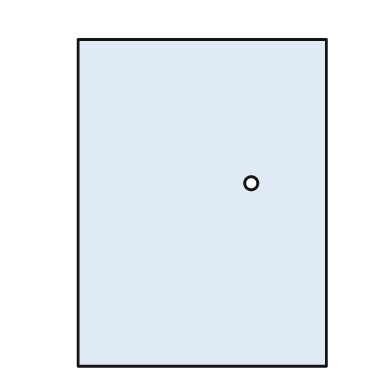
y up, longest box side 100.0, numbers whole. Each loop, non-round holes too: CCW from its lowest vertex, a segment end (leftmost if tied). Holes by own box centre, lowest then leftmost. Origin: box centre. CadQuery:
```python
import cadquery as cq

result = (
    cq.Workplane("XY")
    .moveTo(-38.0, -50.0)
    .lineTo(38.0, -50.0)
    .lineTo(38.0, 50.0)
    .lineTo(-38.0, 50.0)
    .close()
    .moveTo(15.0, 6.0)
    .circle(2.0)
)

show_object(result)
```